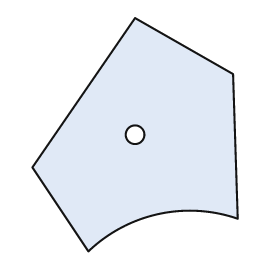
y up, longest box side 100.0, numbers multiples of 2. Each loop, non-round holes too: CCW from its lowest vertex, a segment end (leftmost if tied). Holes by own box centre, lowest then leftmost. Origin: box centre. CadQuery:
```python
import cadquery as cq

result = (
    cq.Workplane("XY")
    .moveTo(-20.0, -50.0)
    .threePointArc((10.0, -34.0), (44.0, -36.0))
    .lineTo(42.0, 26.0)
    .lineTo(0.0, 50.0)
    .lineTo(-44.0, -14.0)
    .close()
    .moveTo(0.0, 0.0)
    .circle(4.0)
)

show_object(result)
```